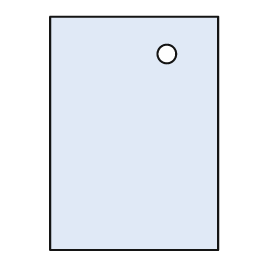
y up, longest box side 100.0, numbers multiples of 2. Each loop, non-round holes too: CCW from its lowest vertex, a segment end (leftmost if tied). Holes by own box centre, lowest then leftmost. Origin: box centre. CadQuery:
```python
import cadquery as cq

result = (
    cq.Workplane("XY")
    .moveTo(-36.0, -50.0)
    .lineTo(36.0, -50.0)
    .lineTo(36.0, 50.0)
    .lineTo(-36.0, 50.0)
    .close()
    .moveTo(14.0, 34.0)
    .circle(4.0)
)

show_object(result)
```